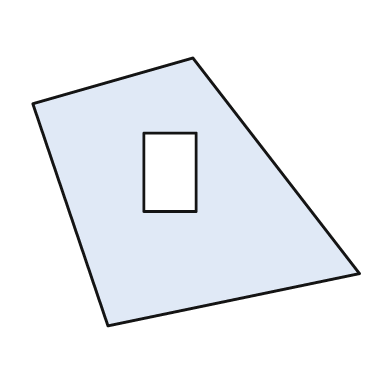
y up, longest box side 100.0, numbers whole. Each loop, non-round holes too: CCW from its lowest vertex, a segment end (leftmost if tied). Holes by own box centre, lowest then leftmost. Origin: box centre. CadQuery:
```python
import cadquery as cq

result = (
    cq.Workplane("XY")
    .moveTo(-27.0, -41.0)
    .lineTo(50.0, -25.0)
    .lineTo(-1.0, 41.0)
    .lineTo(-50.0, 27.0)
    .close()
    .moveTo(-16.0, -6.0)
    .lineTo(0.0, -6.0)
    .lineTo(0.0, 18.0)
    .lineTo(-16.0, 18.0)
    .close()
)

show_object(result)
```